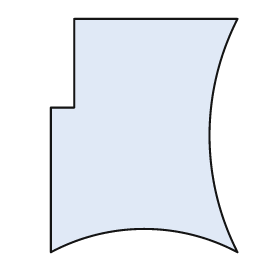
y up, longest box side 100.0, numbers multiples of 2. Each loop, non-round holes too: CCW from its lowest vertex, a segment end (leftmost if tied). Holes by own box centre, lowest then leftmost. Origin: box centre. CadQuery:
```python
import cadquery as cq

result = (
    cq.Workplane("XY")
    .moveTo(-40.0, -50.0)
    .threePointArc((0.0, -40.0), (40.0, -50.0))
    .threePointArc((28.0, 0.0), (40.0, 50.0))
    .lineTo(-30.0, 50.0)
    .lineTo(-30.0, 12.0)
    .lineTo(-40.0, 12.0)
    .close()
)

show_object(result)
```